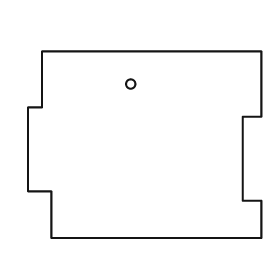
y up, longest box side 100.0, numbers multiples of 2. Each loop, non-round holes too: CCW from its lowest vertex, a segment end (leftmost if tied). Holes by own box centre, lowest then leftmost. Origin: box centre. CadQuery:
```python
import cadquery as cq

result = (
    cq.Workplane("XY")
    .moveTo(-40.0, -40.0)
    .lineTo(50.0, -40.0)
    .lineTo(50.0, -24.0)
    .lineTo(42.0, -24.0)
    .lineTo(42.0, 12.0)
    .lineTo(50.0, 12.0)
    .lineTo(50.0, 40.0)
    .lineTo(-44.0, 40.0)
    .lineTo(-44.0, 16.0)
    .lineTo(-50.0, 16.0)
    .lineTo(-50.0, -20.0)
    .lineTo(-40.0, -20.0)
    .close()
    .moveTo(-6.0, 26.0)
    .circle(2.0)
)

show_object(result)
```